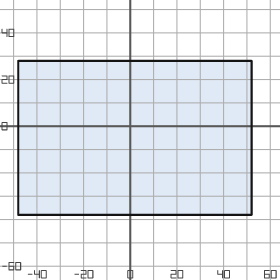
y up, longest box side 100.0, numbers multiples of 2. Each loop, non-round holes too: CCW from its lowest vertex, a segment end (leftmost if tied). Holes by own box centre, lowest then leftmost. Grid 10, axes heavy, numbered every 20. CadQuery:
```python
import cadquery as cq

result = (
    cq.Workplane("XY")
    .moveTo(-48.0, -38.0)
    .lineTo(52.0, -38.0)
    .lineTo(52.0, 28.0)
    .lineTo(-48.0, 28.0)
    .close()
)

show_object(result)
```